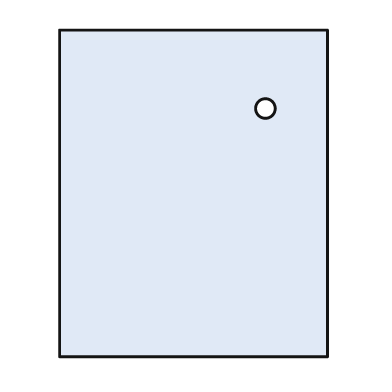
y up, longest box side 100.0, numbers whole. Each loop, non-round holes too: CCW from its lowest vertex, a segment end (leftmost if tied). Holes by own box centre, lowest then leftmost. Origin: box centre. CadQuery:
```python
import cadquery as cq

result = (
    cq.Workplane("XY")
    .moveTo(-41.0, -50.0)
    .lineTo(41.0, -50.0)
    .lineTo(41.0, 50.0)
    .lineTo(-41.0, 50.0)
    .close()
    .moveTo(22.0, 26.0)
    .circle(3.0)
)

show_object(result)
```